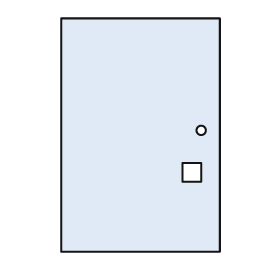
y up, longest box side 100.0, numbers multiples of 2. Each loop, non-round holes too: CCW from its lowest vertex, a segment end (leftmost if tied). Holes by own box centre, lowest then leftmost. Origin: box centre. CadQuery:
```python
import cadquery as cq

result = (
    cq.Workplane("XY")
    .moveTo(-34.0, -50.0)
    .lineTo(34.0, -50.0)
    .lineTo(34.0, 50.0)
    .lineTo(-34.0, 50.0)
    .close()
    .moveTo(18.0, -20.0)
    .lineTo(26.0, -20.0)
    .lineTo(26.0, -12.0)
    .lineTo(18.0, -12.0)
    .close()
    .moveTo(26.0, 2.0)
    .circle(2.0)
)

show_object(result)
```